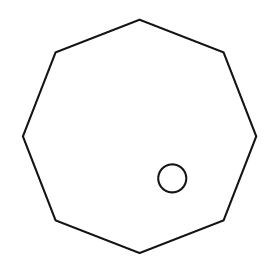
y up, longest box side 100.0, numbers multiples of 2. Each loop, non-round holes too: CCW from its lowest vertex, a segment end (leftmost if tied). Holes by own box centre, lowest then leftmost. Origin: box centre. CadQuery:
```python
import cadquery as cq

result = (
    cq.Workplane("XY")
    .moveTo(0.0, -50.0)
    .lineTo(36.0, -36.0)
    .lineTo(50.0, 0.0)
    .lineTo(36.0, 36.0)
    .lineTo(0.0, 50.0)
    .lineTo(-36.0, 36.0)
    .lineTo(-50.0, 0.0)
    .lineTo(-36.0, -36.0)
    .close()
    .moveTo(14.0, -18.0)
    .circle(6.0)
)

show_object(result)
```